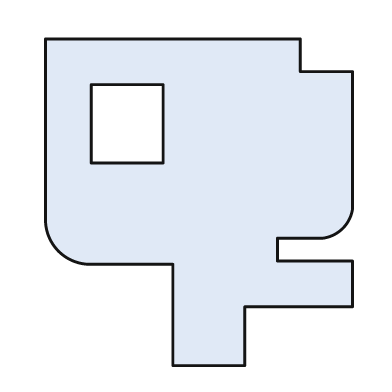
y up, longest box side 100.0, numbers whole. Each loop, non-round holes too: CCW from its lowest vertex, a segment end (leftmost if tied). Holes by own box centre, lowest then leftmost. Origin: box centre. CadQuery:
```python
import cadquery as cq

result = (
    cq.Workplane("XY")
    .moveTo(-8.0, -50.0)
    .lineTo(14.0, -50.0)
    .lineTo(14.0, -32.0)
    .lineTo(47.0, -32.0)
    .lineTo(47.0, -18.0)
    .lineTo(24.0, -18.0)
    .lineTo(24.0, -11.0)
    .lineTo(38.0, -11.0)
    .threePointArc((44.0, -8.0), (47.0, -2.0))
    .lineTo(47.0, 40.0)
    .lineTo(31.0, 40.0)
    .lineTo(31.0, 50.0)
    .lineTo(-47.0, 50.0)
    .lineTo(-47.0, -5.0)
    .threePointArc((-43.0, -15.0), (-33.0, -19.0))
    .lineTo(-8.0, -19.0)
    .close()
    .moveTo(-33.0, 12.0)
    .lineTo(-11.0, 12.0)
    .lineTo(-11.0, 36.0)
    .lineTo(-33.0, 36.0)
    .close()
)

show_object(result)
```